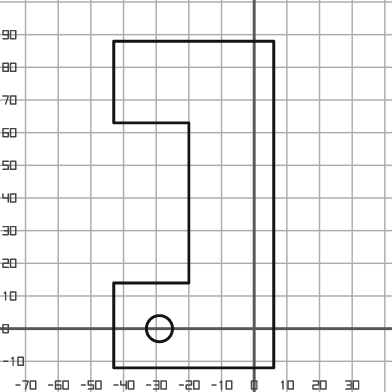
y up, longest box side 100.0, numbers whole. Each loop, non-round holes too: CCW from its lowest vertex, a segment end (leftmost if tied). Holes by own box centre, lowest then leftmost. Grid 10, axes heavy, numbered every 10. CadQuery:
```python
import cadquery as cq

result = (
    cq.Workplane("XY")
    .moveTo(-43.0, -12.0)
    .lineTo(6.0, -12.0)
    .lineTo(6.0, 88.0)
    .lineTo(-43.0, 88.0)
    .lineTo(-43.0, 63.0)
    .lineTo(-20.0, 63.0)
    .lineTo(-20.0, 14.0)
    .lineTo(-43.0, 14.0)
    .close()
    .moveTo(-29.0, 0.0)
    .circle(4.0)
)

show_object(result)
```